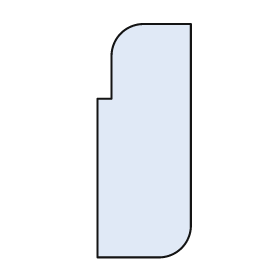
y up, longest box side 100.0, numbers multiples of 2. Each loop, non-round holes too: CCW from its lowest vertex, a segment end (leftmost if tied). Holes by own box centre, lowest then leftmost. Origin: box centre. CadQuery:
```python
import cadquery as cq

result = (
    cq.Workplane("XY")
    .moveTo(-20.0, -50.0)
    .lineTo(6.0, -50.0)
    .threePointArc((16.0, -46.0), (20.0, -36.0))
    .lineTo(20.0, 50.0)
    .lineTo(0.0, 50.0)
    .threePointArc((-10.0, 46.0), (-14.0, 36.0))
    .lineTo(-14.0, 18.0)
    .lineTo(-20.0, 18.0)
    .close()
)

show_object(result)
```